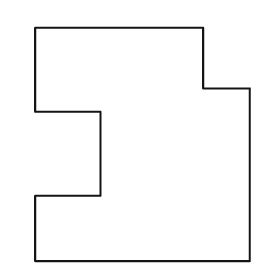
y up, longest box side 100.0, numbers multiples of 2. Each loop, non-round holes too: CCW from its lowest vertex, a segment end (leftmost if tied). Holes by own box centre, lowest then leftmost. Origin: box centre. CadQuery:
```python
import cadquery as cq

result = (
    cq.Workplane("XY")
    .moveTo(-46.0, -50.0)
    .lineTo(46.0, -50.0)
    .lineTo(46.0, 24.0)
    .lineTo(26.0, 24.0)
    .lineTo(26.0, 50.0)
    .lineTo(-46.0, 50.0)
    .lineTo(-46.0, 14.0)
    .lineTo(-18.0, 14.0)
    .lineTo(-18.0, -22.0)
    .lineTo(-46.0, -22.0)
    .close()
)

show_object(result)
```